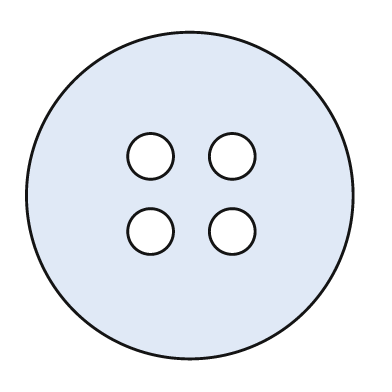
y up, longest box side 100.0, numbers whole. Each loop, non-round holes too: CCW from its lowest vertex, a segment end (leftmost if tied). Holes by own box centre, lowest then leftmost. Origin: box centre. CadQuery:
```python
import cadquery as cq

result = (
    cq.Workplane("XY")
    .moveTo(0.0, 0.0)
    .circle(50.0)
    .moveTo(-12.0, -11.0)
    .circle(7.0)
    .moveTo(13.0, -11.0)
    .circle(7.0)
    .moveTo(-12.0, 12.0)
    .circle(7.0)
    .moveTo(13.0, 12.0)
    .circle(7.0)
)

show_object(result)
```